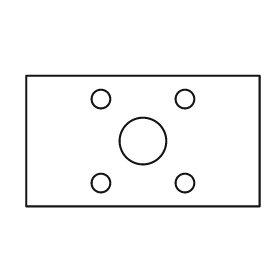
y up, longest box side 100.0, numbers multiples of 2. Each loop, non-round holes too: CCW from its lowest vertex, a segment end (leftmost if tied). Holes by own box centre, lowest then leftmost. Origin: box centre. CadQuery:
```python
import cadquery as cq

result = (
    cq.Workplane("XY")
    .moveTo(-50.0, -28.0)
    .lineTo(50.0, -28.0)
    .lineTo(50.0, 28.0)
    .lineTo(-50.0, 28.0)
    .close()
    .moveTo(-18.0, -18.0)
    .circle(4.0)
    .moveTo(18.0, -18.0)
    .circle(4.0)
    .moveTo(0.0, 0.0)
    .circle(10.0)
    .moveTo(-18.0, 18.0)
    .circle(4.0)
    .moveTo(18.0, 18.0)
    .circle(4.0)
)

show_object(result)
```